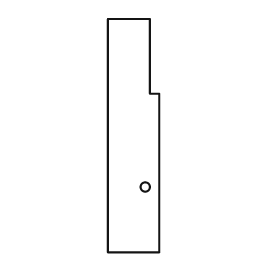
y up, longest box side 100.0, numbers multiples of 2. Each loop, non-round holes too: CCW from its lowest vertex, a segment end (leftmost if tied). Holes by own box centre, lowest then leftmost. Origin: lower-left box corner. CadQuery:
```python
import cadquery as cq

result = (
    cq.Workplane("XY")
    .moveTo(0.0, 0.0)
    .lineTo(22.0, 0.0)
    .lineTo(22.0, 68.0)
    .lineTo(18.0, 68.0)
    .lineTo(18.0, 100.0)
    .lineTo(0.0, 100.0)
    .close()
    .moveTo(16.0, 28.0)
    .circle(2.0)
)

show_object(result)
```